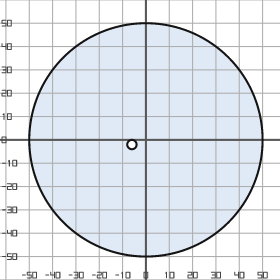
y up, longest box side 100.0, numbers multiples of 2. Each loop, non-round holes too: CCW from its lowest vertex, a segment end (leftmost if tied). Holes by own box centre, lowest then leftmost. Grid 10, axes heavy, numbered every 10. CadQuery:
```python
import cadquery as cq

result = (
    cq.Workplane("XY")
    .moveTo(0.0, 0.0)
    .circle(50.0)
    .moveTo(-6.0, -2.0)
    .circle(2.0)
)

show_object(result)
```